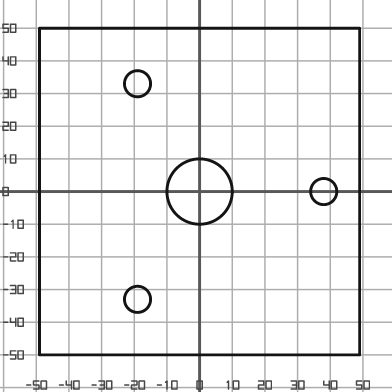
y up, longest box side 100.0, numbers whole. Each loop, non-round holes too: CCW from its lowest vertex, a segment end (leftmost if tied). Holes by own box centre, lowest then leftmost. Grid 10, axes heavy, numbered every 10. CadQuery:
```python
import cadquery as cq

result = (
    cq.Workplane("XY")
    .moveTo(-49.0, -50.0)
    .lineTo(49.0, -50.0)
    .lineTo(49.0, 50.0)
    .lineTo(-49.0, 50.0)
    .close()
    .moveTo(-19.0, -33.0)
    .circle(4.0)
    .moveTo(0.0, 0.0)
    .circle(10.0)
    .moveTo(38.0, 0.0)
    .circle(4.0)
    .moveTo(-19.0, 33.0)
    .circle(4.0)
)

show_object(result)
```